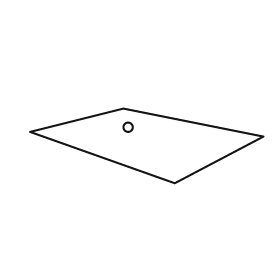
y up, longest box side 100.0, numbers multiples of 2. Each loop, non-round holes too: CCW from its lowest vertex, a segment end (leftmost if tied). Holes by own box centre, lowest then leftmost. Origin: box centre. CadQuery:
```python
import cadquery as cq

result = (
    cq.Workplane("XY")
    .moveTo(12.0, -16.0)
    .lineTo(50.0, 4.0)
    .lineTo(-10.0, 16.0)
    .lineTo(-50.0, 6.0)
    .close()
    .moveTo(-8.0, 8.0)
    .circle(2.0)
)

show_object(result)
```